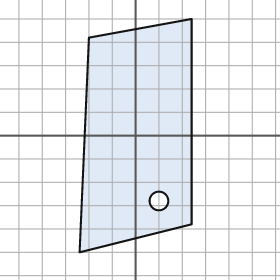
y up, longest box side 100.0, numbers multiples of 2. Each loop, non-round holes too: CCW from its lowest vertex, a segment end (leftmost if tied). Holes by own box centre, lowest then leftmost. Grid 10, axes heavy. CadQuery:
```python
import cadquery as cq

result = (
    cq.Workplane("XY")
    .moveTo(-24.0, -50.0)
    .lineTo(24.0, -38.0)
    .lineTo(24.0, 50.0)
    .lineTo(-20.0, 42.0)
    .close()
    .moveTo(10.0, -28.0)
    .circle(4.0)
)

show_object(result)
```